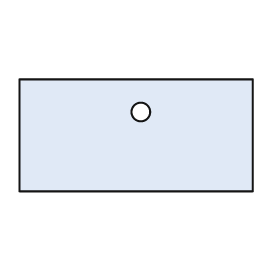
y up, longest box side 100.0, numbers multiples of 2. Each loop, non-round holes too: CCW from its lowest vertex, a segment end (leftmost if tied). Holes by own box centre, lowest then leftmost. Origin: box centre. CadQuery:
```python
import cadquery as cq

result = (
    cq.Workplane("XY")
    .moveTo(-50.0, -24.0)
    .lineTo(50.0, -24.0)
    .lineTo(50.0, 24.0)
    .lineTo(-50.0, 24.0)
    .close()
    .moveTo(2.0, 10.0)
    .circle(4.0)
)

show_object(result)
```